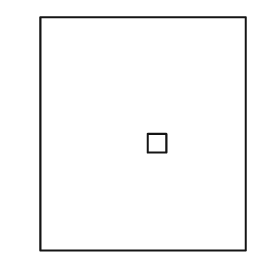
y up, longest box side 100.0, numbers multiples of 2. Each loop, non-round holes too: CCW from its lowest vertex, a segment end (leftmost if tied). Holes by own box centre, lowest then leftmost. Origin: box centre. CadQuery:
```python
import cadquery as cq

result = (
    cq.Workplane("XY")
    .moveTo(-44.0, -50.0)
    .lineTo(44.0, -50.0)
    .lineTo(44.0, 50.0)
    .lineTo(-44.0, 50.0)
    .close()
    .moveTo(2.0, -8.0)
    .lineTo(10.0, -8.0)
    .lineTo(10.0, 0.0)
    .lineTo(2.0, 0.0)
    .close()
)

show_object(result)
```